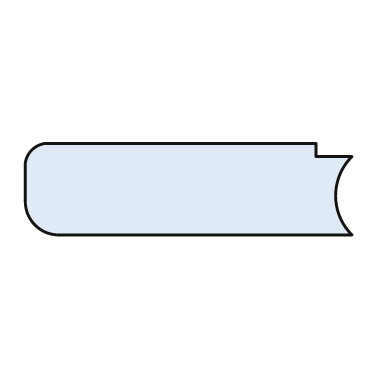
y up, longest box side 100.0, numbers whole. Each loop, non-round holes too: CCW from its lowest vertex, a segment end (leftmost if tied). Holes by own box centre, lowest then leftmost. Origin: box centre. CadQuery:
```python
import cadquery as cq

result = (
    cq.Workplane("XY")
    .moveTo(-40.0, -14.0)
    .lineTo(50.0, -14.0)
    .threePointArc((45.0, -2.0), (50.0, 10.0))
    .lineTo(39.0, 10.0)
    .lineTo(39.0, 14.0)
    .lineTo(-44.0, 14.0)
    .threePointArc((-48.0, 12.0), (-50.0, 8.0))
    .lineTo(-50.0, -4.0)
    .threePointArc((-47.0, -11.0), (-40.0, -14.0))
    .close()
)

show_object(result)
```